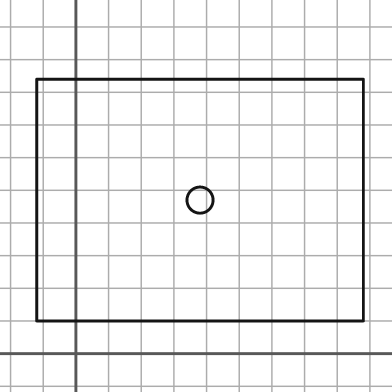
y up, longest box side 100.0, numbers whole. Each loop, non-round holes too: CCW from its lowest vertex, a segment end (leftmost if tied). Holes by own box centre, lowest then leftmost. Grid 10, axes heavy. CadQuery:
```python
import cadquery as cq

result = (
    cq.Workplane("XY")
    .moveTo(-12.0, 10.0)
    .lineTo(88.0, 10.0)
    .lineTo(88.0, 84.0)
    .lineTo(-12.0, 84.0)
    .close()
    .moveTo(38.0, 47.0)
    .circle(4.0)
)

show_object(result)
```